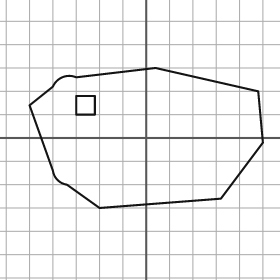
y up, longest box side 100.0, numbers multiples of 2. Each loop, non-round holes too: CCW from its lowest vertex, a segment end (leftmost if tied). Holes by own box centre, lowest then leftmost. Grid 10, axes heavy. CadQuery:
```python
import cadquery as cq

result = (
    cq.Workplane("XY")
    .moveTo(-20.0, -30.0)
    .lineTo(32.0, -26.0)
    .lineTo(50.0, -2.0)
    .lineTo(48.0, 20.0)
    .lineTo(4.0, 30.0)
    .lineTo(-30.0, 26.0)
    .threePointArc((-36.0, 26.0), (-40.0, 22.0))
    .lineTo(-50.0, 14.0)
    .lineTo(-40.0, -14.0)
    .threePointArc((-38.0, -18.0), (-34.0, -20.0))
    .close()
    .moveTo(-30.0, 10.0)
    .lineTo(-22.0, 10.0)
    .lineTo(-22.0, 18.0)
    .lineTo(-30.0, 18.0)
    .close()
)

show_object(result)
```